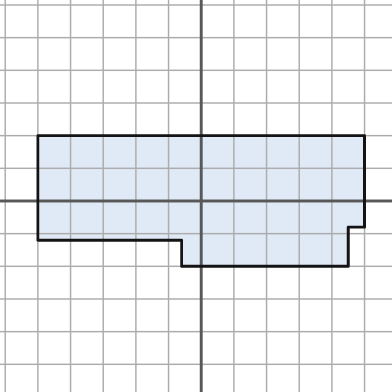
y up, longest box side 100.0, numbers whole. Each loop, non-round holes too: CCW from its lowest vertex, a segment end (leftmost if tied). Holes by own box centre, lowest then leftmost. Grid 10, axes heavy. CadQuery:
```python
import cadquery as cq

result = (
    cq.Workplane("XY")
    .moveTo(-6.0, -20.0)
    .lineTo(45.0, -20.0)
    .lineTo(45.0, -8.0)
    .lineTo(50.0, -8.0)
    .lineTo(50.0, 20.0)
    .lineTo(-50.0, 20.0)
    .lineTo(-50.0, -12.0)
    .lineTo(-6.0, -12.0)
    .close()
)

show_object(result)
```